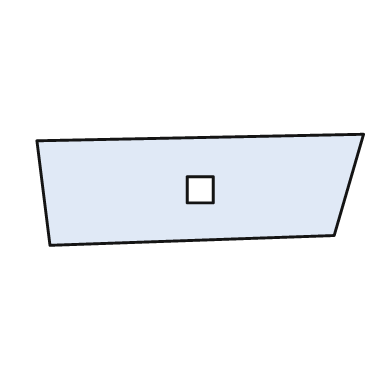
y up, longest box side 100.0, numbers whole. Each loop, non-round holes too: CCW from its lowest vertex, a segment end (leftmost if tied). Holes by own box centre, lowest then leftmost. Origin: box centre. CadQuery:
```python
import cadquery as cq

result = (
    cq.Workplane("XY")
    .moveTo(-46.0, -17.0)
    .lineTo(41.0, -14.0)
    .lineTo(50.0, 17.0)
    .lineTo(-50.0, 15.0)
    .close()
    .moveTo(-4.0, -4.0)
    .lineTo(4.0, -4.0)
    .lineTo(4.0, 4.0)
    .lineTo(-4.0, 4.0)
    .close()
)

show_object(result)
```